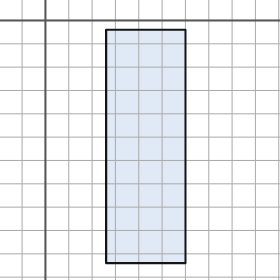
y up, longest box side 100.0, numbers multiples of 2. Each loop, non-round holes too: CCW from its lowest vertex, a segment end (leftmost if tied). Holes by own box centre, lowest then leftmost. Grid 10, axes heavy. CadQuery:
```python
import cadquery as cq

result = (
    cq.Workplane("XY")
    .moveTo(26.0, -104.0)
    .lineTo(60.0, -104.0)
    .lineTo(60.0, -4.0)
    .lineTo(26.0, -4.0)
    .close()
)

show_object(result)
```